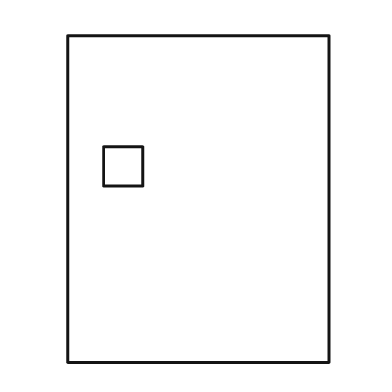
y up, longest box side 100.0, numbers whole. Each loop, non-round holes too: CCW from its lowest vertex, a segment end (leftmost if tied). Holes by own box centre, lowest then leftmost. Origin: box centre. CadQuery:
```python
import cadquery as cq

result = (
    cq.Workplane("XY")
    .moveTo(-40.0, -50.0)
    .lineTo(40.0, -50.0)
    .lineTo(40.0, 50.0)
    .lineTo(-40.0, 50.0)
    .close()
    .moveTo(-29.0, 4.0)
    .lineTo(-17.0, 4.0)
    .lineTo(-17.0, 16.0)
    .lineTo(-29.0, 16.0)
    .close()
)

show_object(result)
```